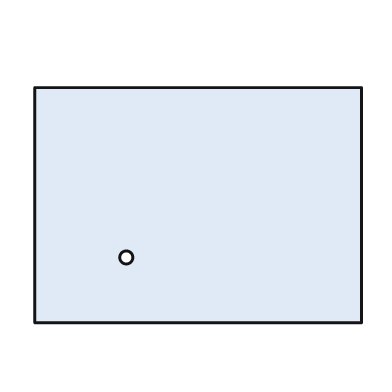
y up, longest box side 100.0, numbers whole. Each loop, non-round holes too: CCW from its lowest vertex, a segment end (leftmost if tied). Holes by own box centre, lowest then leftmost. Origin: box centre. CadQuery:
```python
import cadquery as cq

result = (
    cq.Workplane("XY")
    .moveTo(-50.0, -36.0)
    .lineTo(50.0, -36.0)
    .lineTo(50.0, 36.0)
    .lineTo(-50.0, 36.0)
    .close()
    .moveTo(-22.0, -16.0)
    .circle(2.0)
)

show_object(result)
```